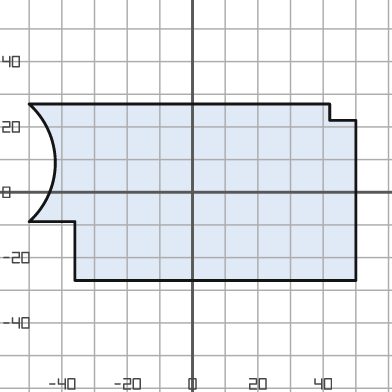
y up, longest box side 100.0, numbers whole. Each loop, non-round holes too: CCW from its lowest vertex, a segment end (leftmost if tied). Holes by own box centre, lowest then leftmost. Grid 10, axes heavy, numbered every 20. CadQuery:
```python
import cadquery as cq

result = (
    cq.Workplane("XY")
    .moveTo(-36.0, -27.0)
    .lineTo(50.0, -27.0)
    .lineTo(50.0, 22.0)
    .lineTo(42.0, 22.0)
    .lineTo(42.0, 27.0)
    .lineTo(-50.0, 27.0)
    .threePointArc((-42.0, 9.0), (-50.0, -9.0))
    .lineTo(-36.0, -9.0)
    .close()
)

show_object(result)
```